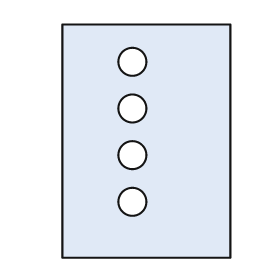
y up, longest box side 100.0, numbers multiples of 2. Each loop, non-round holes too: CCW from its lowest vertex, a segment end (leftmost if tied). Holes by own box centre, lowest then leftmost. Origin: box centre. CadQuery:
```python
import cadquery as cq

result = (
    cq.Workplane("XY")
    .moveTo(-36.0, -50.0)
    .lineTo(36.0, -50.0)
    .lineTo(36.0, 50.0)
    .lineTo(-36.0, 50.0)
    .close()
    .moveTo(-6.0, -26.0)
    .circle(6.0)
    .moveTo(-6.0, -6.0)
    .circle(6.0)
    .moveTo(-6.0, 14.0)
    .circle(6.0)
    .moveTo(-6.0, 34.0)
    .circle(6.0)
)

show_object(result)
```